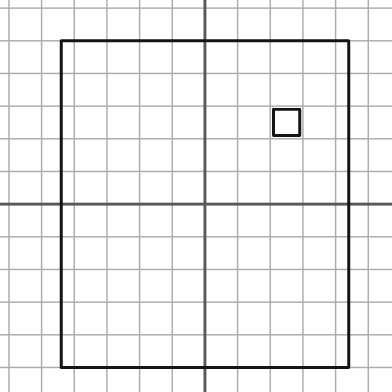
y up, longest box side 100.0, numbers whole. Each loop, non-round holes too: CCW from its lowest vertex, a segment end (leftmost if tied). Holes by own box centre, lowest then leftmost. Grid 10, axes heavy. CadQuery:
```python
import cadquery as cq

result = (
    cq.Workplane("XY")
    .moveTo(-44.0, -50.0)
    .lineTo(44.0, -50.0)
    .lineTo(44.0, 50.0)
    .lineTo(-44.0, 50.0)
    .close()
    .moveTo(21.0, 21.0)
    .lineTo(29.0, 21.0)
    .lineTo(29.0, 29.0)
    .lineTo(21.0, 29.0)
    .close()
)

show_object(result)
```